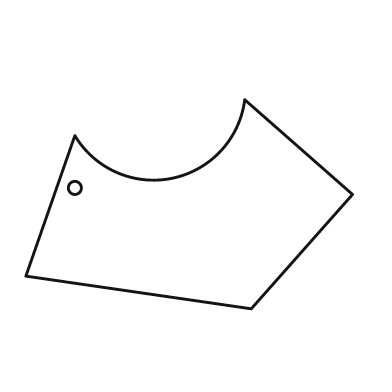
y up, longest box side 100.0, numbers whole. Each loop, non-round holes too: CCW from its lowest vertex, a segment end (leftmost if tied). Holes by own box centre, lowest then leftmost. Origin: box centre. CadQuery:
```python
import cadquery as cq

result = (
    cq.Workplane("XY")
    .moveTo(19.0, -32.0)
    .lineTo(50.0, 3.0)
    .lineTo(17.0, 32.0)
    .threePointArc((-5.0, 8.0), (-35.0, 21.0))
    .lineTo(-50.0, -22.0)
    .close()
    .moveTo(-35.0, 5.0)
    .circle(2.0)
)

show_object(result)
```